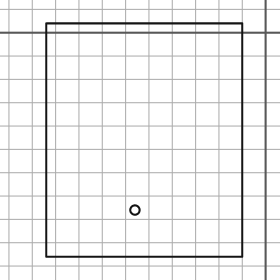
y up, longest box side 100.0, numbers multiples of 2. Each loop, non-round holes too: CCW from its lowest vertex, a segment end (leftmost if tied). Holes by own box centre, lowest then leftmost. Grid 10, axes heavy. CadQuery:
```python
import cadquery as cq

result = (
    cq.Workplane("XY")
    .moveTo(-94.0, -96.0)
    .lineTo(-10.0, -96.0)
    .lineTo(-10.0, 4.0)
    .lineTo(-94.0, 4.0)
    .close()
    .moveTo(-56.0, -76.0)
    .circle(2.0)
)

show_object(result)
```